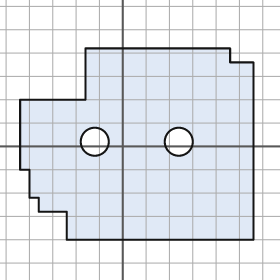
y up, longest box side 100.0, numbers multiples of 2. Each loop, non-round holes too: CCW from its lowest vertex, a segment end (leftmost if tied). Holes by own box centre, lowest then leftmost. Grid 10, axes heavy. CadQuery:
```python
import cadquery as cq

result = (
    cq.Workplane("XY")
    .moveTo(-24.0, -40.0)
    .lineTo(56.0, -40.0)
    .lineTo(56.0, 36.0)
    .lineTo(46.0, 36.0)
    .lineTo(46.0, 42.0)
    .lineTo(-16.0, 42.0)
    .lineTo(-16.0, 20.0)
    .lineTo(-44.0, 20.0)
    .lineTo(-44.0, -10.0)
    .lineTo(-40.0, -10.0)
    .lineTo(-40.0, -22.0)
    .lineTo(-36.0, -22.0)
    .lineTo(-36.0, -28.0)
    .lineTo(-24.0, -28.0)
    .close()
    .moveTo(-12.0, 2.0)
    .circle(6.0)
    .moveTo(24.0, 2.0)
    .circle(6.0)
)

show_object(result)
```